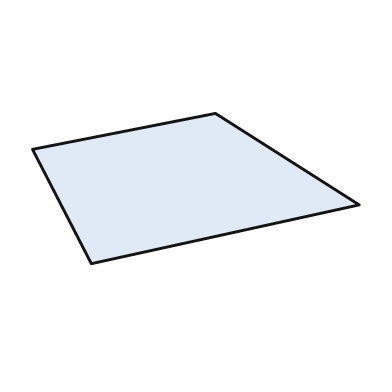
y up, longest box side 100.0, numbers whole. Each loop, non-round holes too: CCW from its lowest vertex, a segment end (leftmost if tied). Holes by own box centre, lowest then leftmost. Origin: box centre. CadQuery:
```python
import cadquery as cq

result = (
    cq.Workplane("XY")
    .moveTo(-32.0, -23.0)
    .lineTo(50.0, -5.0)
    .lineTo(6.0, 23.0)
    .lineTo(-50.0, 12.0)
    .close()
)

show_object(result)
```